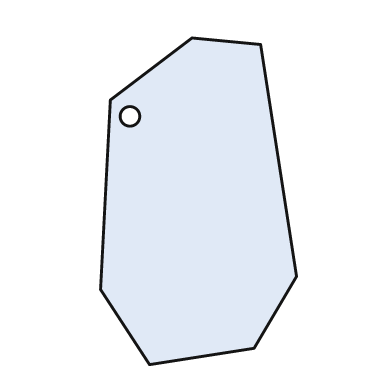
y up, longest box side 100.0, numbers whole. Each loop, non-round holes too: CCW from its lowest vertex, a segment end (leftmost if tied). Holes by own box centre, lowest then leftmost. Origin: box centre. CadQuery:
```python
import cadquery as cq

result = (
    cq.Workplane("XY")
    .moveTo(-15.0, -50.0)
    .lineTo(17.0, -45.0)
    .lineTo(30.0, -23.0)
    .lineTo(19.0, 48.0)
    .lineTo(-2.0, 50.0)
    .lineTo(-27.0, 31.0)
    .lineTo(-30.0, -27.0)
    .close()
    .moveTo(-21.0, 26.0)
    .circle(3.0)
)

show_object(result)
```